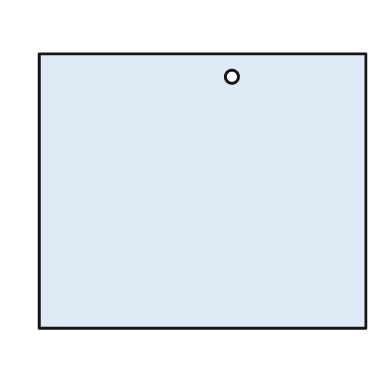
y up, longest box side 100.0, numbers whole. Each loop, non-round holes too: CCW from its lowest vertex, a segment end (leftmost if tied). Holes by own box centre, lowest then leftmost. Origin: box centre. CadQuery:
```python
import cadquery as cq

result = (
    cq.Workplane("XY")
    .moveTo(-50.0, -42.0)
    .lineTo(50.0, -42.0)
    .lineTo(50.0, 42.0)
    .lineTo(-50.0, 42.0)
    .close()
    .moveTo(9.0, 35.0)
    .circle(2.0)
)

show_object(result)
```